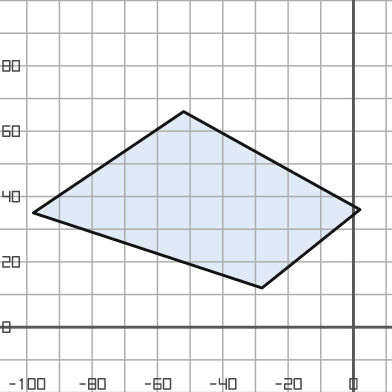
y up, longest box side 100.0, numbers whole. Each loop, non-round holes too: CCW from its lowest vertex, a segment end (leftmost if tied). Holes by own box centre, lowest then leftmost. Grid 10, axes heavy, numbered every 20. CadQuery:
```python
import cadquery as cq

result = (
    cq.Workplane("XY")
    .moveTo(-28.0, 12.0)
    .lineTo(2.0, 36.0)
    .lineTo(-52.0, 66.0)
    .lineTo(-98.0, 35.0)
    .close()
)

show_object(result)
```